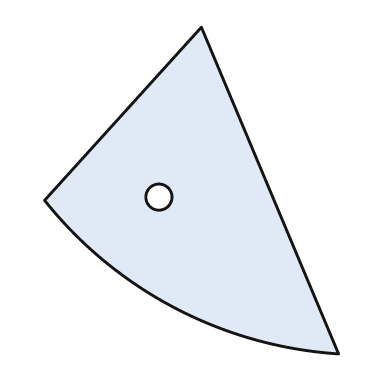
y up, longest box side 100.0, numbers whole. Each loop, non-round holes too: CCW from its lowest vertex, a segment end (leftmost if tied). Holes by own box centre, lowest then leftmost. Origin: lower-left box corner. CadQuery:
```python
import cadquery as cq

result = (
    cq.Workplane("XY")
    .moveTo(90.0, 0.0)
    .lineTo(48.0, 100.0)
    .lineTo(0.0, 47.0)
    .threePointArc((40.0, 14.0), (90.0, 0.0))
    .close()
    .moveTo(35.0, 48.0)
    .circle(4.0)
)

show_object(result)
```